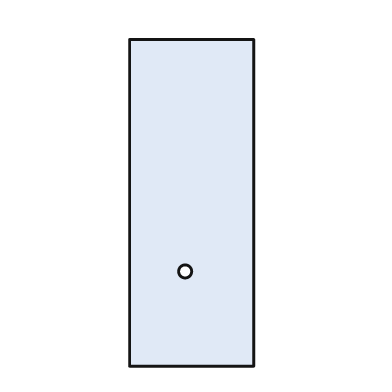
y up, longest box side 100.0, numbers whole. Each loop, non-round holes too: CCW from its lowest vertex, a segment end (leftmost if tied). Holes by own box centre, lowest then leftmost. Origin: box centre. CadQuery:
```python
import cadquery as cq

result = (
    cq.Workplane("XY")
    .moveTo(-19.0, -50.0)
    .lineTo(19.0, -50.0)
    .lineTo(19.0, 50.0)
    .lineTo(-19.0, 50.0)
    .close()
    .moveTo(-2.0, -21.0)
    .circle(2.0)
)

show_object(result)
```